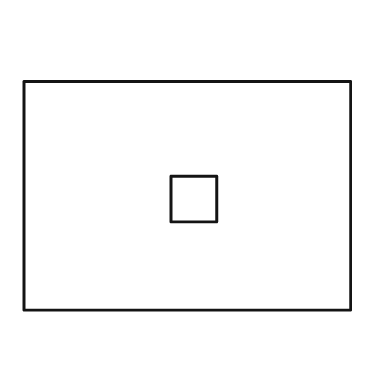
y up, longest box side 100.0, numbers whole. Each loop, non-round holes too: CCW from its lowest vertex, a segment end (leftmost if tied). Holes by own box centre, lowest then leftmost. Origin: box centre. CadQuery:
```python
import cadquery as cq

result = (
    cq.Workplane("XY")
    .moveTo(-50.0, -35.0)
    .lineTo(50.0, -35.0)
    .lineTo(50.0, 35.0)
    .lineTo(-50.0, 35.0)
    .close()
    .moveTo(-5.0, -8.0)
    .lineTo(9.0, -8.0)
    .lineTo(9.0, 6.0)
    .lineTo(-5.0, 6.0)
    .close()
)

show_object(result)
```